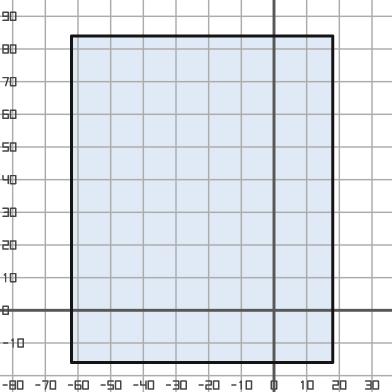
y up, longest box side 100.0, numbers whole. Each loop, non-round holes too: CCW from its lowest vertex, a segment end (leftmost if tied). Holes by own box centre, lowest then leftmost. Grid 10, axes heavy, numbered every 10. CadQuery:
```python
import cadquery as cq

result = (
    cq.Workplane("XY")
    .moveTo(-62.0, -16.0)
    .lineTo(18.0, -16.0)
    .lineTo(18.0, 84.0)
    .lineTo(-62.0, 84.0)
    .close()
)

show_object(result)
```